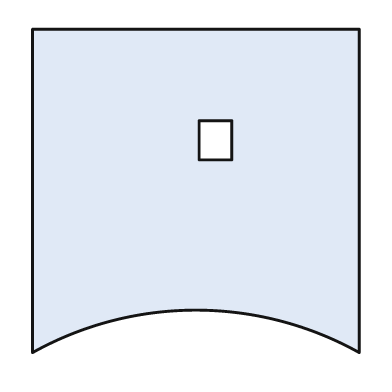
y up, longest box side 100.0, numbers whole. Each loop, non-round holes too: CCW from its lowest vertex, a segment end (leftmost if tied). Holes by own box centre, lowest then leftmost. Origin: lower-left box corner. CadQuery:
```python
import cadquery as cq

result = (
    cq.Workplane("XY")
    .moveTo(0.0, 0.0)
    .threePointArc((50.0, 13.0), (100.0, 0.0))
    .lineTo(100.0, 99.0)
    .lineTo(0.0, 99.0)
    .close()
    .moveTo(51.0, 59.0)
    .lineTo(61.0, 59.0)
    .lineTo(61.0, 71.0)
    .lineTo(51.0, 71.0)
    .close()
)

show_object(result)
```